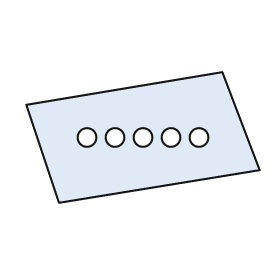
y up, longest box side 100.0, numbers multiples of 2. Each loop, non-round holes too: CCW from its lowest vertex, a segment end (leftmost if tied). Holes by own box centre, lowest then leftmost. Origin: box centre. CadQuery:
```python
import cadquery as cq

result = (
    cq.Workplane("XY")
    .moveTo(-36.0, -28.0)
    .lineTo(50.0, -14.0)
    .lineTo(34.0, 28.0)
    .lineTo(-50.0, 14.0)
    .close()
    .moveTo(-24.0, 0.0)
    .circle(4.0)
    .moveTo(-12.0, 0.0)
    .circle(4.0)
    .moveTo(0.0, 0.0)
    .circle(4.0)
    .moveTo(12.0, 0.0)
    .circle(4.0)
    .moveTo(24.0, 0.0)
    .circle(4.0)
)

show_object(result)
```